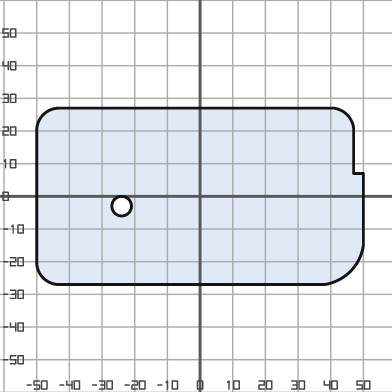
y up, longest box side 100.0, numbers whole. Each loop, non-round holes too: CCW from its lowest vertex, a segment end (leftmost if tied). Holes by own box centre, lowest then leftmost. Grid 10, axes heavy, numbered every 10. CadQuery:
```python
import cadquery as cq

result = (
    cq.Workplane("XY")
    .moveTo(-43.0, -27.0)
    .lineTo(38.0, -27.0)
    .threePointArc((46.0, -23.0), (50.0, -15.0))
    .lineTo(50.0, 7.0)
    .lineTo(47.0, 7.0)
    .lineTo(47.0, 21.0)
    .threePointArc((45.0, 25.0), (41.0, 27.0))
    .lineTo(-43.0, 27.0)
    .threePointArc((-48.0, 25.0), (-50.0, 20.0))
    .lineTo(-50.0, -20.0)
    .threePointArc((-48.0, -25.0), (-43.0, -27.0))
    .close()
    .moveTo(-24.0, -3.0)
    .circle(3.0)
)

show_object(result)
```